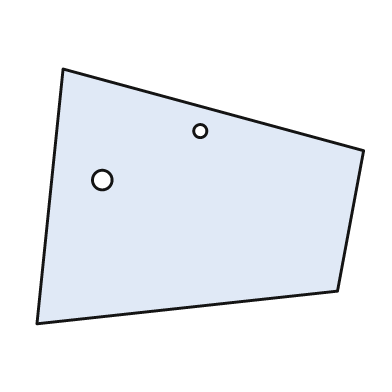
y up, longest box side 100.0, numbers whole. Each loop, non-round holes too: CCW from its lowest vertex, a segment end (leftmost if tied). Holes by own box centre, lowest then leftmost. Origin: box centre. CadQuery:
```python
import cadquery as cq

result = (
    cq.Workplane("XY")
    .moveTo(-50.0, -39.0)
    .lineTo(42.0, -29.0)
    .lineTo(50.0, 14.0)
    .lineTo(-42.0, 39.0)
    .close()
    .moveTo(-30.0, 5.0)
    .circle(3.0)
    .moveTo(0.0, 20.0)
    .circle(2.0)
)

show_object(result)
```